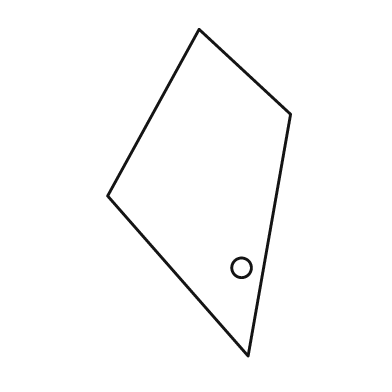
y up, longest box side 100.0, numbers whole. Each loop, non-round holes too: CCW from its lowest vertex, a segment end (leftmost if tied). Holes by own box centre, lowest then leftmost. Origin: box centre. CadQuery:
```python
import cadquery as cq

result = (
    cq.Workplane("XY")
    .moveTo(15.0, -50.0)
    .lineTo(28.0, 24.0)
    .lineTo(0.0, 50.0)
    .lineTo(-28.0, -1.0)
    .close()
    .moveTo(13.0, -23.0)
    .circle(3.0)
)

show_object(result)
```